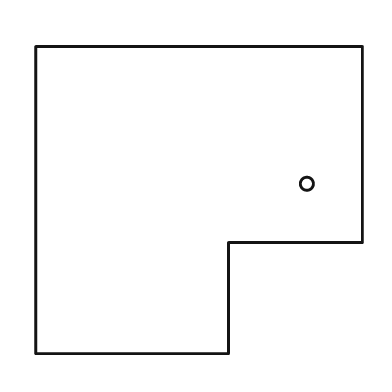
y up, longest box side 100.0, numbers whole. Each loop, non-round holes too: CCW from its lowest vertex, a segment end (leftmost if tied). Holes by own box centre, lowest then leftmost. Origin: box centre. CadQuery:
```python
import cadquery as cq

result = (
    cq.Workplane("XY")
    .moveTo(-50.0, -47.0)
    .lineTo(9.0, -47.0)
    .lineTo(9.0, -13.0)
    .lineTo(50.0, -13.0)
    .lineTo(50.0, 47.0)
    .lineTo(-50.0, 47.0)
    .close()
    .moveTo(33.0, 5.0)
    .circle(2.0)
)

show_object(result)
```